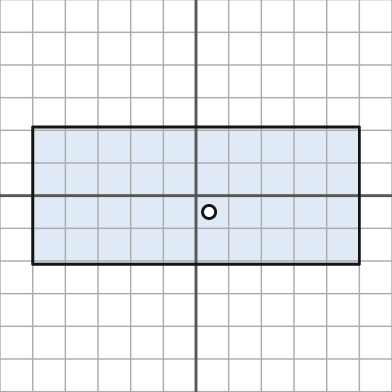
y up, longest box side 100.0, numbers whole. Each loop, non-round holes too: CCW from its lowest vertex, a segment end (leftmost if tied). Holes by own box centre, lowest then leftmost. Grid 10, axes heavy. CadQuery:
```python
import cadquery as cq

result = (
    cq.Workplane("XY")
    .moveTo(-50.0, -21.0)
    .lineTo(50.0, -21.0)
    .lineTo(50.0, 21.0)
    .lineTo(-50.0, 21.0)
    .close()
    .moveTo(4.0, -5.0)
    .circle(2.0)
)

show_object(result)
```